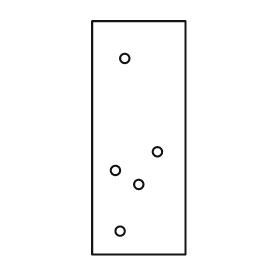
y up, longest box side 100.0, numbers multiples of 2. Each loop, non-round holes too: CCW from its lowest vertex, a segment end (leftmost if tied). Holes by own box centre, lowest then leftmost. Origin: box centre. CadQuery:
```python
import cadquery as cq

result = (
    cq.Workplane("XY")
    .moveTo(-20.0, -50.0)
    .lineTo(20.0, -50.0)
    .lineTo(20.0, 50.0)
    .lineTo(-20.0, 50.0)
    .close()
    .moveTo(-8.0, -40.0)
    .circle(2.0)
    .moveTo(0.0, -20.0)
    .circle(2.0)
    .moveTo(-10.0, -14.0)
    .circle(2.0)
    .moveTo(8.0, -6.0)
    .circle(2.0)
    .moveTo(-6.0, 34.0)
    .circle(2.0)
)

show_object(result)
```